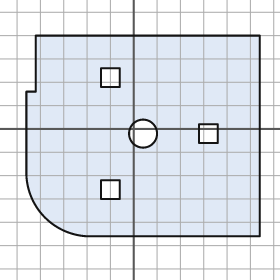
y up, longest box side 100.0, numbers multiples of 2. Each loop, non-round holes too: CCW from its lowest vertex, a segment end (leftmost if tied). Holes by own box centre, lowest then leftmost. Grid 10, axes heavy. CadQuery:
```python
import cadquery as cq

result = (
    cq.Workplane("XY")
    .moveTo(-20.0, -46.0)
    .lineTo(54.0, -46.0)
    .lineTo(54.0, 40.0)
    .lineTo(-42.0, 40.0)
    .lineTo(-42.0, 16.0)
    .lineTo(-46.0, 16.0)
    .lineTo(-46.0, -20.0)
    .threePointArc((-38.0, -38.0), (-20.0, -46.0))
    .close()
    .moveTo(-14.0, -30.0)
    .lineTo(-6.0, -30.0)
    .lineTo(-6.0, -22.0)
    .lineTo(-14.0, -22.0)
    .close()
    .moveTo(4.0, -2.0)
    .circle(6.0)
    .moveTo(28.0, -6.0)
    .lineTo(36.0, -6.0)
    .lineTo(36.0, 2.0)
    .lineTo(28.0, 2.0)
    .close()
    .moveTo(-14.0, 18.0)
    .lineTo(-6.0, 18.0)
    .lineTo(-6.0, 26.0)
    .lineTo(-14.0, 26.0)
    .close()
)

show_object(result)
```